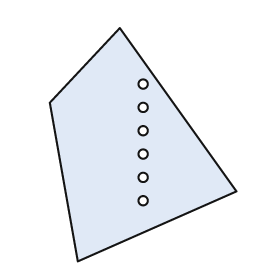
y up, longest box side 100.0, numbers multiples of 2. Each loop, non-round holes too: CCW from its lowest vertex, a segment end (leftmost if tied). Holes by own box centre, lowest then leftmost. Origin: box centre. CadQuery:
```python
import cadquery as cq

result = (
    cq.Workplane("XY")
    .moveTo(-28.0, -50.0)
    .lineTo(40.0, -20.0)
    .lineTo(-10.0, 50.0)
    .lineTo(-40.0, 18.0)
    .close()
    .moveTo(0.0, -24.0)
    .circle(2.0)
    .moveTo(0.0, -14.0)
    .circle(2.0)
    .moveTo(0.0, -4.0)
    .circle(2.0)
    .moveTo(0.0, 6.0)
    .circle(2.0)
    .moveTo(0.0, 16.0)
    .circle(2.0)
    .moveTo(0.0, 26.0)
    .circle(2.0)
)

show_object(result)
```